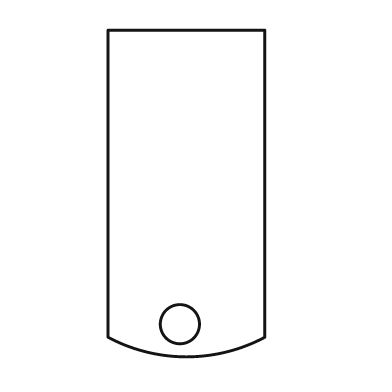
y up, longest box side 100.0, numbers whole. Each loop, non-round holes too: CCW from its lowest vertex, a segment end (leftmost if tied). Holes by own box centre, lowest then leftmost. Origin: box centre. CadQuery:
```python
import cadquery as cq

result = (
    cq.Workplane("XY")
    .moveTo(-24.0, -44.0)
    .threePointArc((0.0, -50.0), (24.0, -44.0))
    .lineTo(24.0, 50.0)
    .lineTo(-24.0, 50.0)
    .close()
    .moveTo(-2.0, -40.0)
    .circle(6.0)
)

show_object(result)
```